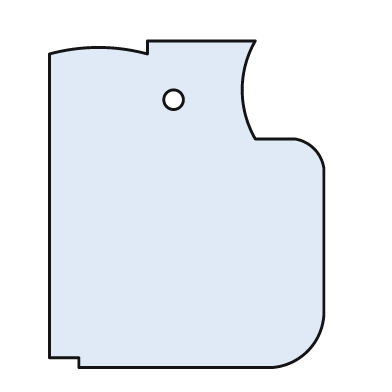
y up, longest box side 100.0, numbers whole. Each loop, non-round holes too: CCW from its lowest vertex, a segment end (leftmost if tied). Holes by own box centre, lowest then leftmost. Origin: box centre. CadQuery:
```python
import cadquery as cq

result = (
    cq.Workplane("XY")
    .moveTo(-33.0, -50.0)
    .lineTo(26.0, -50.0)
    .threePointArc((37.0, -45.0), (42.0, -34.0))
    .lineTo(42.0, 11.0)
    .threePointArc((39.0, 17.0), (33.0, 20.0))
    .lineTo(21.0, 20.0)
    .threePointArc((17.0, 35.0), (21.0, 50.0))
    .lineTo(-12.0, 50.0)
    .lineTo(-12.0, 46.0)
    .threePointArc((-27.0, 48.0), (-42.0, 46.0))
    .lineTo(-42.0, -47.0)
    .lineTo(-33.0, -47.0)
    .close()
    .moveTo(-4.0, 32.0)
    .circle(3.0)
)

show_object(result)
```